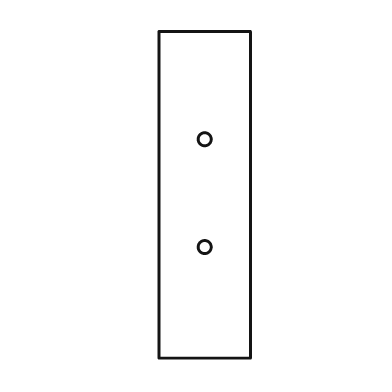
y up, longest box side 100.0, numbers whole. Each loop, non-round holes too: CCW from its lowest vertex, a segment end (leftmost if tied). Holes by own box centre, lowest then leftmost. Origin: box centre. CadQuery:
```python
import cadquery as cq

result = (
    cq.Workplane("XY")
    .moveTo(-14.0, -50.0)
    .lineTo(14.0, -50.0)
    .lineTo(14.0, 50.0)
    .lineTo(-14.0, 50.0)
    .close()
    .moveTo(0.0, -16.0)
    .circle(2.0)
    .moveTo(0.0, 17.0)
    .circle(2.0)
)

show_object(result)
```